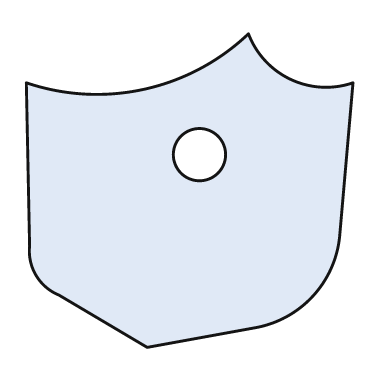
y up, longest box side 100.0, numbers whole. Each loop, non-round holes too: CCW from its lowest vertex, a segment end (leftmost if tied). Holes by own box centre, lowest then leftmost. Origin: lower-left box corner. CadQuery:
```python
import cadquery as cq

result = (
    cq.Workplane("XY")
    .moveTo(37.0, 0.0)
    .lineTo(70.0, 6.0)
    .threePointArc((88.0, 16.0), (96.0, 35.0))
    .lineTo(100.0, 81.0)
    .threePointArc((81.0, 82.0), (68.0, 96.0))
    .threePointArc((36.0, 79.0), (0.0, 81.0))
    .lineTo(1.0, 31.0)
    .threePointArc((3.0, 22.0), (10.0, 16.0))
    .close()
    .moveTo(53.0, 59.0)
    .circle(8.0)
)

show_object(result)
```